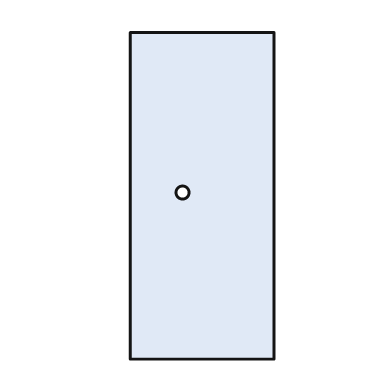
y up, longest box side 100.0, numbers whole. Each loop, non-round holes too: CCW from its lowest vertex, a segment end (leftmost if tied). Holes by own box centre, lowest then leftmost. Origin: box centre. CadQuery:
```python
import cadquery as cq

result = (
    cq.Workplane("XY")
    .moveTo(-22.0, -50.0)
    .lineTo(22.0, -50.0)
    .lineTo(22.0, 50.0)
    .lineTo(-22.0, 50.0)
    .close()
    .moveTo(-6.0, 1.0)
    .circle(2.0)
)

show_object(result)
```